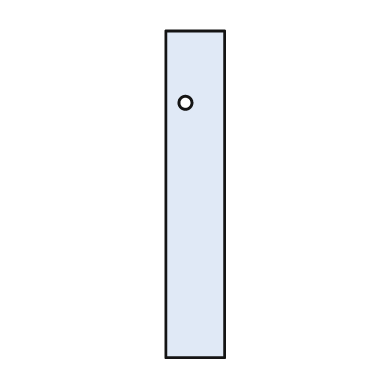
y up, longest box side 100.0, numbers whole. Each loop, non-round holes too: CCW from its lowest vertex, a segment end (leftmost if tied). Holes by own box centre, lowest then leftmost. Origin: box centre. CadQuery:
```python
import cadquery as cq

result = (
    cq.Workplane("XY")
    .moveTo(-9.0, -50.0)
    .lineTo(9.0, -50.0)
    .lineTo(9.0, 50.0)
    .lineTo(-9.0, 50.0)
    .close()
    .moveTo(-3.0, 28.0)
    .circle(2.0)
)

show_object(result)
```